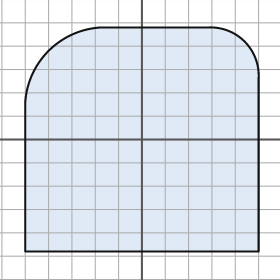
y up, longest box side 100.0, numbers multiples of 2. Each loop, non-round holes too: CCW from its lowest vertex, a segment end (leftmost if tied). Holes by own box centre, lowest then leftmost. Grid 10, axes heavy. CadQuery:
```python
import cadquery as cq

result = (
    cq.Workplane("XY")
    .moveTo(-50.0, -48.0)
    .lineTo(50.0, -48.0)
    .lineTo(50.0, 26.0)
    .threePointArc((44.0, 42.0), (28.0, 48.0))
    .lineTo(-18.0, 48.0)
    .threePointArc((-40.0, 38.0), (-50.0, 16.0))
    .close()
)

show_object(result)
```